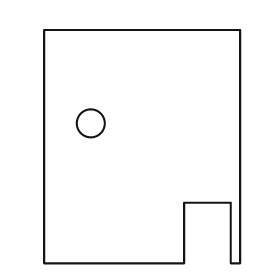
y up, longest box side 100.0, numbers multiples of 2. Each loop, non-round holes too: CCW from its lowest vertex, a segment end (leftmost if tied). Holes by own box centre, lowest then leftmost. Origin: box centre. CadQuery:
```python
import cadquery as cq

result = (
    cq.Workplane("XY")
    .moveTo(-42.0, -50.0)
    .lineTo(18.0, -50.0)
    .lineTo(18.0, -24.0)
    .lineTo(38.0, -24.0)
    .lineTo(38.0, -50.0)
    .lineTo(42.0, -50.0)
    .lineTo(42.0, 50.0)
    .lineTo(-42.0, 50.0)
    .close()
    .moveTo(-22.0, 10.0)
    .circle(6.0)
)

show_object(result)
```